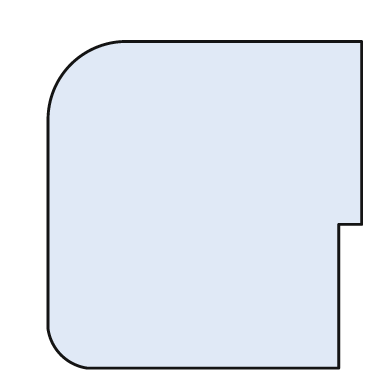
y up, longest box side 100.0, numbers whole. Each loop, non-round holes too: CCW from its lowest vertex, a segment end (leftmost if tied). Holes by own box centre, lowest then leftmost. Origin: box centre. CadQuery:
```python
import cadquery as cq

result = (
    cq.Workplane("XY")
    .moveTo(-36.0, -50.0)
    .lineTo(41.0, -50.0)
    .lineTo(41.0, -6.0)
    .lineTo(48.0, -6.0)
    .lineTo(48.0, 50.0)
    .lineTo(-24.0, 50.0)
    .threePointArc((-41.0, 43.0), (-48.0, 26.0))
    .lineTo(-48.0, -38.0)
    .threePointArc((-44.0, -46.0), (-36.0, -50.0))
    .close()
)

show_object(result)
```